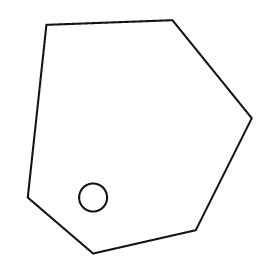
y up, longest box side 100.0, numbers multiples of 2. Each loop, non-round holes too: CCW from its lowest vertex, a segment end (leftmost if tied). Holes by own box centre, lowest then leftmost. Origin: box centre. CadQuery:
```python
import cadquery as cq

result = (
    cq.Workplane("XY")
    .moveTo(-20.0, -50.0)
    .lineTo(24.0, -40.0)
    .lineTo(48.0, 8.0)
    .lineTo(14.0, 50.0)
    .lineTo(-40.0, 48.0)
    .lineTo(-48.0, -26.0)
    .close()
    .moveTo(-20.0, -26.0)
    .circle(6.0)
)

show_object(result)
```